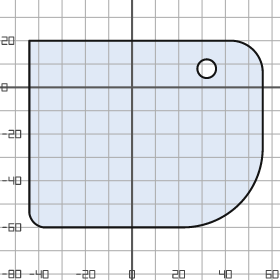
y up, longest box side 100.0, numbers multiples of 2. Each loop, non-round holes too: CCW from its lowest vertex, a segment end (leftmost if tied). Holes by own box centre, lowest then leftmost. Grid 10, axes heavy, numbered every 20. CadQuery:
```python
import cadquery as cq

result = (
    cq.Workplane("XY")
    .moveTo(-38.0, -60.0)
    .lineTo(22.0, -60.0)
    .threePointArc((46.0, -50.0), (56.0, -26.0))
    .lineTo(56.0, 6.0)
    .threePointArc((52.0, 16.0), (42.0, 20.0))
    .lineTo(-44.0, 20.0)
    .lineTo(-44.0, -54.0)
    .threePointArc((-42.0, -58.0), (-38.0, -60.0))
    .close()
    .moveTo(32.0, 8.0)
    .circle(4.0)
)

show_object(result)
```